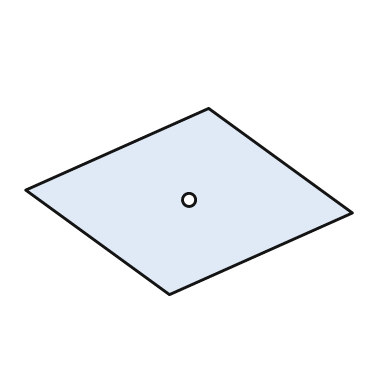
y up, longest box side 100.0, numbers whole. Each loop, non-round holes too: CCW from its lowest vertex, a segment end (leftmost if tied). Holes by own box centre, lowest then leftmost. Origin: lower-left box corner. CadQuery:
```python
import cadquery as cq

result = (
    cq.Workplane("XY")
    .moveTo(44.0, 0.0)
    .lineTo(100.0, 25.0)
    .lineTo(56.0, 57.0)
    .lineTo(0.0, 32.0)
    .close()
    .moveTo(50.0, 29.0)
    .circle(2.0)
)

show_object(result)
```